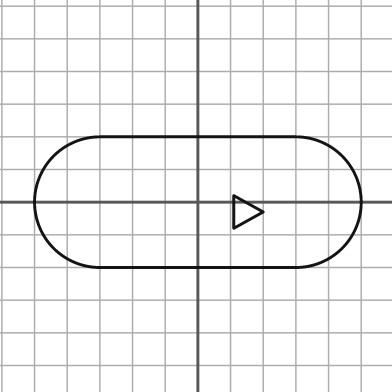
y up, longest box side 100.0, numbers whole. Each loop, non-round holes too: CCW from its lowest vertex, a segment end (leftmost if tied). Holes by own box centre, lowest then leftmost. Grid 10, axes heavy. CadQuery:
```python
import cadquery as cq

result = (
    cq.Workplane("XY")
    .moveTo(-30.0, -20.0)
    .lineTo(30.0, -20.0)
    .threePointArc((50.0, 0.0), (30.0, 20.0))
    .lineTo(-30.0, 20.0)
    .threePointArc((-50.0, 0.0), (-30.0, -20.0))
    .close()
    .moveTo(11.0, -8.0)
    .lineTo(20.0, -3.0)
    .lineTo(11.0, 2.0)
    .close()
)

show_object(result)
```